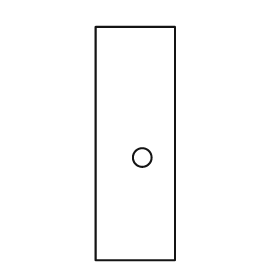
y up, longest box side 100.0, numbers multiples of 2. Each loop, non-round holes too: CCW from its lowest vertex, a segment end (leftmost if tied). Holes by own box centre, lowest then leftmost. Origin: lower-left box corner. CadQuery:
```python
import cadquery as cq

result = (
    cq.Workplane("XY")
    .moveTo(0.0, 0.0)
    .lineTo(34.0, 0.0)
    .lineTo(34.0, 100.0)
    .lineTo(0.0, 100.0)
    .close()
    .moveTo(20.0, 44.0)
    .circle(4.0)
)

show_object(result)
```